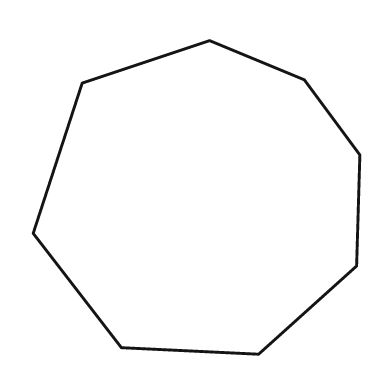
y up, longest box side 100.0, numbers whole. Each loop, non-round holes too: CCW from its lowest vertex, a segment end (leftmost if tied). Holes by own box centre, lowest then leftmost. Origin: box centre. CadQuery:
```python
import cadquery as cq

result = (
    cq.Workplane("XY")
    .moveTo(19.0, -48.0)
    .lineTo(49.0, -21.0)
    .lineTo(50.0, 13.0)
    .lineTo(33.0, 36.0)
    .lineTo(4.0, 48.0)
    .lineTo(-35.0, 35.0)
    .lineTo(-50.0, -11.0)
    .lineTo(-23.0, -46.0)
    .close()
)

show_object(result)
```